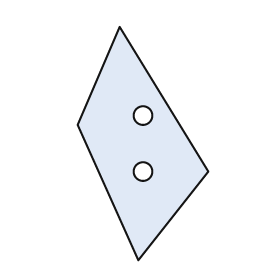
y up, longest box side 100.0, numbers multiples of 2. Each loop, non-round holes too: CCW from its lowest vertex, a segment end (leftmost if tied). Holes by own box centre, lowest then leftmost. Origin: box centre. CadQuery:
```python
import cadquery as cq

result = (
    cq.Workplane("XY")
    .moveTo(-2.0, -50.0)
    .lineTo(28.0, -12.0)
    .lineTo(-10.0, 50.0)
    .lineTo(-28.0, 8.0)
    .close()
    .moveTo(0.0, -12.0)
    .circle(4.0)
    .moveTo(0.0, 12.0)
    .circle(4.0)
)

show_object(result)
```